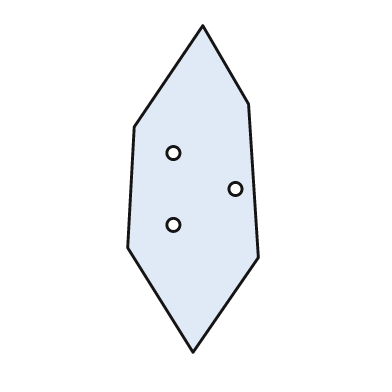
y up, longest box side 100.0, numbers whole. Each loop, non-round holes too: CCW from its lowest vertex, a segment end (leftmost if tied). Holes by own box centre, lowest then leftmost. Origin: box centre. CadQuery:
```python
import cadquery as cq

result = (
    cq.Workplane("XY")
    .moveTo(0.0, -50.0)
    .lineTo(20.0, -21.0)
    .lineTo(17.0, 26.0)
    .lineTo(3.0, 50.0)
    .lineTo(-18.0, 19.0)
    .lineTo(-20.0, -18.0)
    .close()
    .moveTo(-6.0, -11.0)
    .circle(2.0)
    .moveTo(13.0, 0.0)
    .circle(2.0)
    .moveTo(-6.0, 11.0)
    .circle(2.0)
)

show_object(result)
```